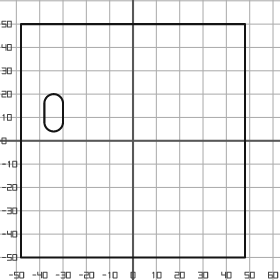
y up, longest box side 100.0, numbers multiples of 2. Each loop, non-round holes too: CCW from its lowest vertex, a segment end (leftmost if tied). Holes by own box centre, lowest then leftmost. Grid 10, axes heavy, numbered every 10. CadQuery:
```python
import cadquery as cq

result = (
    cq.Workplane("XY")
    .moveTo(-48.0, -50.0)
    .lineTo(48.0, -50.0)
    .lineTo(48.0, 50.0)
    .lineTo(-48.0, 50.0)
    .close()
    .moveTo(-38.0, 8.0)
    .threePointArc((-34.0, 4.0), (-30.0, 8.0))
    .lineTo(-30.0, 16.0)
    .threePointArc((-34.0, 20.0), (-38.0, 16.0))
    .close()
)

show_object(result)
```